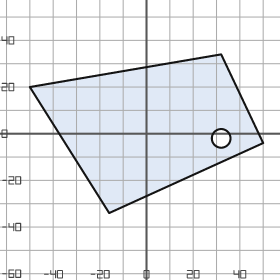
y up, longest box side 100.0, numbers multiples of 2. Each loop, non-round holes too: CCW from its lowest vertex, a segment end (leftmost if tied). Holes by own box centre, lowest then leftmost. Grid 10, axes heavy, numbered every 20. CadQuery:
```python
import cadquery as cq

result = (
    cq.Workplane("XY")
    .moveTo(-16.0, -34.0)
    .lineTo(50.0, -4.0)
    .lineTo(32.0, 34.0)
    .lineTo(-50.0, 20.0)
    .close()
    .moveTo(32.0, -2.0)
    .circle(4.0)
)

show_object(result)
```